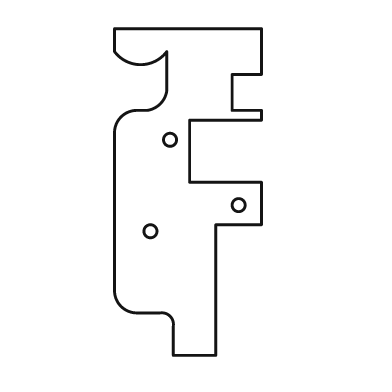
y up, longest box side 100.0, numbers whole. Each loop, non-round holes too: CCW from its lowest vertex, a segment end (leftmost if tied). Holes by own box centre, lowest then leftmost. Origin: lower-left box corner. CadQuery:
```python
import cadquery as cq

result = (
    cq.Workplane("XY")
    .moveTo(18.0, 0.0)
    .lineTo(31.0, 0.0)
    .lineTo(31.0, 40.0)
    .lineTo(45.0, 40.0)
    .lineTo(45.0, 53.0)
    .lineTo(23.0, 53.0)
    .lineTo(23.0, 72.0)
    .lineTo(45.0, 72.0)
    .lineTo(45.0, 75.0)
    .lineTo(36.0, 75.0)
    .lineTo(36.0, 86.0)
    .lineTo(45.0, 86.0)
    .lineTo(45.0, 100.0)
    .lineTo(0.0, 100.0)
    .lineTo(0.0, 93.0)
    .threePointArc((8.0, 89.0), (16.0, 93.0))
    .lineTo(16.0, 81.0)
    .threePointArc((14.0, 77.0), (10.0, 75.0))
    .lineTo(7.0, 75.0)
    .threePointArc((2.0, 73.0), (0.0, 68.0))
    .lineTo(0.0, 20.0)
    .threePointArc((2.0, 15.0), (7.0, 13.0))
    .lineTo(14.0, 13.0)
    .threePointArc((17.0, 12.0), (18.0, 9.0))
    .close()
    .moveTo(11.0, 38.0)
    .circle(2.0)
    .moveTo(38.0, 46.0)
    .circle(2.0)
    .moveTo(17.0, 66.0)
    .circle(2.0)
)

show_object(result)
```